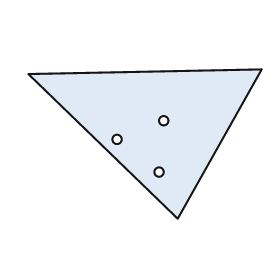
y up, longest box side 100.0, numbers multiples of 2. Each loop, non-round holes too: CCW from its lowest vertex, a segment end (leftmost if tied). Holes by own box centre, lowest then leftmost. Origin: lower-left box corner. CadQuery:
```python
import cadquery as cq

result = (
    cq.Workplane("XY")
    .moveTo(64.0, 0.0)
    .lineTo(100.0, 64.0)
    .lineTo(0.0, 62.0)
    .close()
    .moveTo(56.0, 20.0)
    .circle(2.0)
    .moveTo(38.0, 34.0)
    .circle(2.0)
    .moveTo(58.0, 42.0)
    .circle(2.0)
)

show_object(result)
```